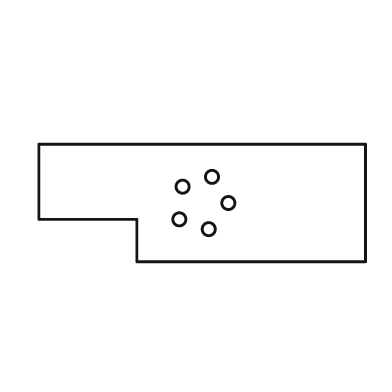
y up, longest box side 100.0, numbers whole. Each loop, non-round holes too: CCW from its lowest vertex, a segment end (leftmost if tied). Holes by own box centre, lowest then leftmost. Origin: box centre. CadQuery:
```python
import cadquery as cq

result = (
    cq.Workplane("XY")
    .moveTo(-20.0, -18.0)
    .lineTo(50.0, -18.0)
    .lineTo(50.0, 18.0)
    .lineTo(-50.0, 18.0)
    .lineTo(-50.0, -5.0)
    .lineTo(-20.0, -5.0)
    .close()
    .moveTo(2.0, -8.0)
    .circle(2.0)
    .moveTo(-7.0, -5.0)
    .circle(2.0)
    .moveTo(8.0, 0.0)
    .circle(2.0)
    .moveTo(-6.0, 5.0)
    .circle(2.0)
    .moveTo(3.0, 8.0)
    .circle(2.0)
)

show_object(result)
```